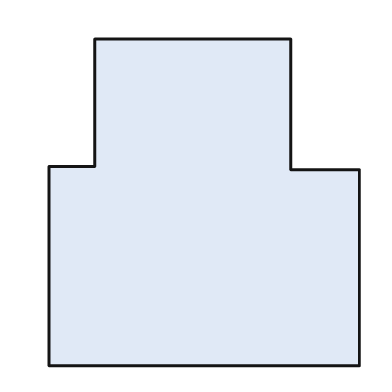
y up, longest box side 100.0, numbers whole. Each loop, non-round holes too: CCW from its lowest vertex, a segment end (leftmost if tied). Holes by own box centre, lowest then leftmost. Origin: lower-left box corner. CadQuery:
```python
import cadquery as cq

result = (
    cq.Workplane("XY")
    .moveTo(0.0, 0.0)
    .lineTo(95.0, 0.0)
    .lineTo(95.0, 60.0)
    .lineTo(74.0, 60.0)
    .lineTo(74.0, 100.0)
    .lineTo(14.0, 100.0)
    .lineTo(14.0, 61.0)
    .lineTo(0.0, 61.0)
    .close()
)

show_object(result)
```